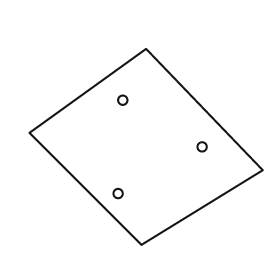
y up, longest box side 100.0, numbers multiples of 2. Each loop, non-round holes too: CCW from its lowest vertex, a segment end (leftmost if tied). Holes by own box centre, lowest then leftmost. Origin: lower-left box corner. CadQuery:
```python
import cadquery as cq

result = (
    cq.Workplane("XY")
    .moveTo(48.0, 0.0)
    .lineTo(100.0, 32.0)
    .lineTo(50.0, 84.0)
    .lineTo(0.0, 48.0)
    .close()
    .moveTo(38.0, 22.0)
    .circle(2.0)
    .moveTo(74.0, 42.0)
    .circle(2.0)
    .moveTo(40.0, 62.0)
    .circle(2.0)
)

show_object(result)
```